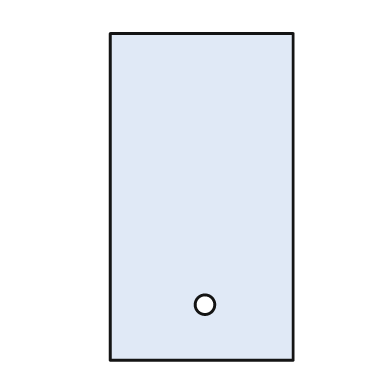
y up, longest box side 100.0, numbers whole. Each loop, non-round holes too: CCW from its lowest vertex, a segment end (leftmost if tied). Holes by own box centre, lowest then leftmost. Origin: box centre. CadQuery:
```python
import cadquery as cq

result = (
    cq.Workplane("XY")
    .moveTo(-28.0, -50.0)
    .lineTo(28.0, -50.0)
    .lineTo(28.0, 50.0)
    .lineTo(-28.0, 50.0)
    .close()
    .moveTo(1.0, -33.0)
    .circle(3.0)
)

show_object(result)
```